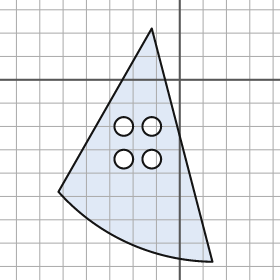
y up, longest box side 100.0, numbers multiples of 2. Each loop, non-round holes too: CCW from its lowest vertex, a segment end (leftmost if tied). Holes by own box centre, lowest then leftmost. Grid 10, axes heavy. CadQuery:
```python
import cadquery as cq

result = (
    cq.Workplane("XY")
    .moveTo(14.0, -78.0)
    .lineTo(-12.0, 22.0)
    .lineTo(-52.0, -48.0)
    .threePointArc((-22.0, -70.0), (14.0, -78.0))
    .close()
    .moveTo(-24.0, -34.0)
    .circle(4.0)
    .moveTo(-12.0, -34.0)
    .circle(4.0)
    .moveTo(-24.0, -20.0)
    .circle(4.0)
    .moveTo(-12.0, -20.0)
    .circle(4.0)
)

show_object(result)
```